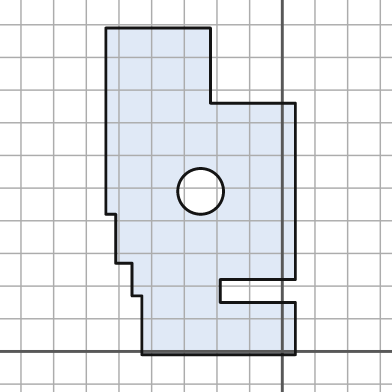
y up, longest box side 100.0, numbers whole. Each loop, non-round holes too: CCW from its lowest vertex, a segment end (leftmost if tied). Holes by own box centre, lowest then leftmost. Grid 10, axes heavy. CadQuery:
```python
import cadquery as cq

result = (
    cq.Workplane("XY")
    .moveTo(-43.0, -1.0)
    .lineTo(4.0, -1.0)
    .lineTo(4.0, 15.0)
    .lineTo(-19.0, 15.0)
    .lineTo(-19.0, 22.0)
    .lineTo(4.0, 22.0)
    .lineTo(4.0, 76.0)
    .lineTo(-22.0, 76.0)
    .lineTo(-22.0, 99.0)
    .lineTo(-54.0, 99.0)
    .lineTo(-54.0, 42.0)
    .lineTo(-51.0, 42.0)
    .lineTo(-51.0, 27.0)
    .lineTo(-46.0, 27.0)
    .lineTo(-46.0, 17.0)
    .lineTo(-43.0, 17.0)
    .close()
    .moveTo(-25.0, 49.0)
    .circle(7.0)
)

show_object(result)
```